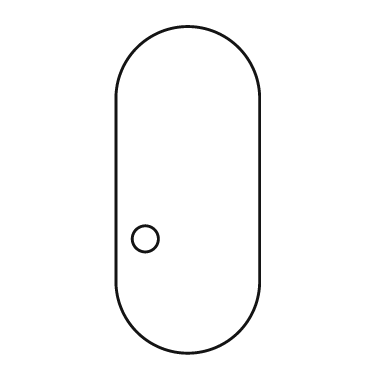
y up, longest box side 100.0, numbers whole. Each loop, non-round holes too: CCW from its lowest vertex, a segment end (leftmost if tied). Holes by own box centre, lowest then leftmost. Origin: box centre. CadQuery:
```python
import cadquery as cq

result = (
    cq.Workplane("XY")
    .moveTo(-22.0, -28.0)
    .threePointArc((0.0, -50.0), (22.0, -28.0))
    .lineTo(22.0, 28.0)
    .threePointArc((0.0, 50.0), (-22.0, 28.0))
    .close()
    .moveTo(-13.0, -15.0)
    .circle(4.0)
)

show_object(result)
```